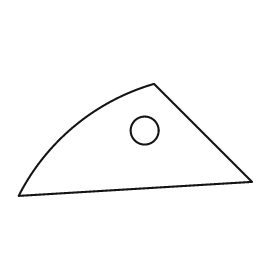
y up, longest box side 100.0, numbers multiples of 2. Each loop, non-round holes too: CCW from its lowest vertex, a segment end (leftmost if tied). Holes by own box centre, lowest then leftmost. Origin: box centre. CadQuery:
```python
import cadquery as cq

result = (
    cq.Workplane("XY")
    .moveTo(-50.0, -24.0)
    .lineTo(50.0, -18.0)
    .lineTo(8.0, 24.0)
    .threePointArc((-26.0, 6.0), (-50.0, -24.0))
    .close()
    .moveTo(4.0, 4.0)
    .circle(6.0)
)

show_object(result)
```